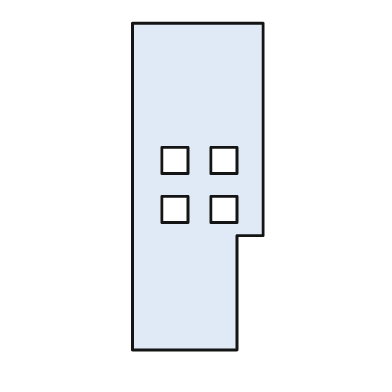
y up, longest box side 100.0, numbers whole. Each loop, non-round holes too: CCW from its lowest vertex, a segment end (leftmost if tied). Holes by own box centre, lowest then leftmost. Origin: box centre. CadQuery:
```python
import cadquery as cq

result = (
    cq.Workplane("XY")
    .moveTo(-20.0, -50.0)
    .lineTo(12.0, -50.0)
    .lineTo(12.0, -15.0)
    .lineTo(20.0, -15.0)
    .lineTo(20.0, 50.0)
    .lineTo(-20.0, 50.0)
    .close()
    .moveTo(-11.0, -11.0)
    .lineTo(-3.0, -11.0)
    .lineTo(-3.0, -3.0)
    .lineTo(-11.0, -3.0)
    .close()
    .moveTo(4.0, -11.0)
    .lineTo(12.0, -11.0)
    .lineTo(12.0, -3.0)
    .lineTo(4.0, -3.0)
    .close()
    .moveTo(-11.0, 4.0)
    .lineTo(-3.0, 4.0)
    .lineTo(-3.0, 12.0)
    .lineTo(-11.0, 12.0)
    .close()
    .moveTo(4.0, 4.0)
    .lineTo(12.0, 4.0)
    .lineTo(12.0, 12.0)
    .lineTo(4.0, 12.0)
    .close()
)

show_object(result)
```